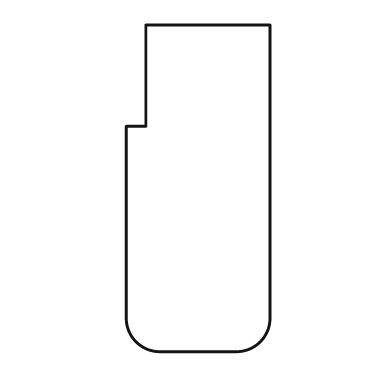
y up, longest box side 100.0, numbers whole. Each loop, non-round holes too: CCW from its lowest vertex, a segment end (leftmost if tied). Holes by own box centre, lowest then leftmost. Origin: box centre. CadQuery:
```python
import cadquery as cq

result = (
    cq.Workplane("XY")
    .moveTo(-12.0, -50.0)
    .lineTo(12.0, -50.0)
    .threePointArc((19.0, -47.0), (22.0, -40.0))
    .lineTo(22.0, 50.0)
    .lineTo(-16.0, 50.0)
    .lineTo(-16.0, 19.0)
    .lineTo(-22.0, 19.0)
    .lineTo(-22.0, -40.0)
    .threePointArc((-19.0, -47.0), (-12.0, -50.0))
    .close()
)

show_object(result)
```